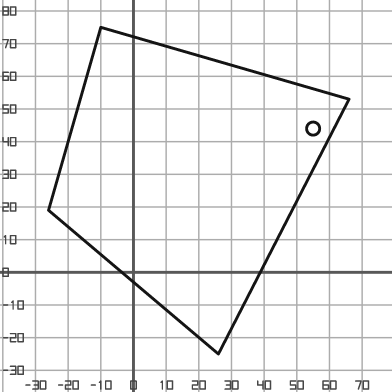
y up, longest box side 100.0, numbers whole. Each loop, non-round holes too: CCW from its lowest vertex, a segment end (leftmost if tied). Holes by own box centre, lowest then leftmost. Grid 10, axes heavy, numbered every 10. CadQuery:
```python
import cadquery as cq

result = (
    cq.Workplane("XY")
    .moveTo(26.0, -25.0)
    .lineTo(66.0, 53.0)
    .lineTo(-10.0, 75.0)
    .lineTo(-26.0, 19.0)
    .close()
    .moveTo(55.0, 44.0)
    .circle(2.0)
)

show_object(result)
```